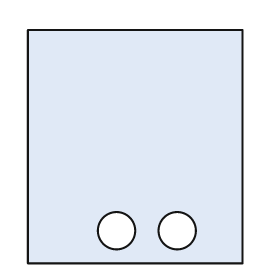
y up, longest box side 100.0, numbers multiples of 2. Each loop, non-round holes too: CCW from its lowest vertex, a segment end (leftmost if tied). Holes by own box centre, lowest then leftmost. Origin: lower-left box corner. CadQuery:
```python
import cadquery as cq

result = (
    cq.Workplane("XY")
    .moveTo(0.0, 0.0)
    .lineTo(92.0, 0.0)
    .lineTo(92.0, 100.0)
    .lineTo(0.0, 100.0)
    .close()
    .moveTo(38.0, 14.0)
    .circle(8.0)
    .moveTo(64.0, 14.0)
    .circle(8.0)
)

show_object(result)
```